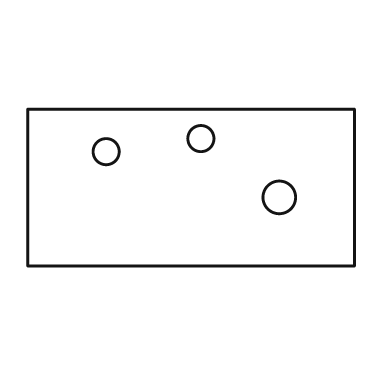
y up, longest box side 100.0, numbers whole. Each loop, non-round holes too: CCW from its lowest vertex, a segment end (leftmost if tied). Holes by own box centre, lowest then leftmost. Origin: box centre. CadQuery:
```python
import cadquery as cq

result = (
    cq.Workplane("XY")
    .moveTo(-50.0, -24.0)
    .lineTo(50.0, -24.0)
    .lineTo(50.0, 24.0)
    .lineTo(-50.0, 24.0)
    .close()
    .moveTo(27.0, -3.0)
    .circle(5.0)
    .moveTo(-26.0, 11.0)
    .circle(4.0)
    .moveTo(3.0, 15.0)
    .circle(4.0)
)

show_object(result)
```